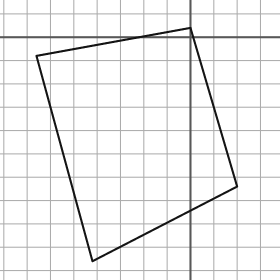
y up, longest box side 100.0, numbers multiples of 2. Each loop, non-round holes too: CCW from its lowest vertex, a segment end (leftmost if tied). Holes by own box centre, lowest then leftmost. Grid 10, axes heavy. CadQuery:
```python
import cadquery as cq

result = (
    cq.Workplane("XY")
    .moveTo(-42.0, -96.0)
    .lineTo(20.0, -64.0)
    .lineTo(0.0, 4.0)
    .lineTo(-66.0, -8.0)
    .close()
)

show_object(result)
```